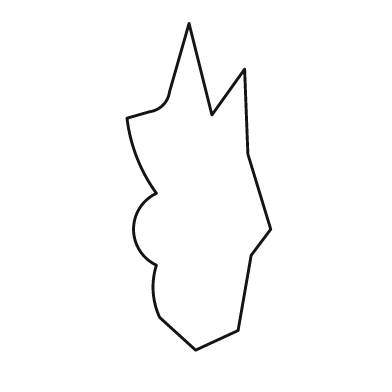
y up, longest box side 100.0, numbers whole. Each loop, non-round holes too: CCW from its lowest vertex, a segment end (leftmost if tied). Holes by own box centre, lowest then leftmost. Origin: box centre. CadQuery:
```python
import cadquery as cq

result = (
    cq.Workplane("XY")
    .moveTo(-1.0, -50.0)
    .lineTo(12.0, -44.0)
    .lineTo(16.0, -21.0)
    .lineTo(22.0, -13.0)
    .lineTo(15.0, 10.0)
    .lineTo(14.0, 36.0)
    .lineTo(4.0, 22.0)
    .lineTo(-3.0, 50.0)
    .lineTo(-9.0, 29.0)
    .threePointArc((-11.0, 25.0), (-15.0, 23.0))
    .lineTo(-22.0, 21.0)
    .threePointArc((-19.0, 9.0), (-13.0, -2.0))
    .threePointArc((-20.0, -13.0), (-13.0, -24.0))
    .threePointArc((-14.0, -32.0), (-12.0, -40.0))
    .close()
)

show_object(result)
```